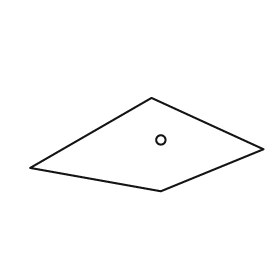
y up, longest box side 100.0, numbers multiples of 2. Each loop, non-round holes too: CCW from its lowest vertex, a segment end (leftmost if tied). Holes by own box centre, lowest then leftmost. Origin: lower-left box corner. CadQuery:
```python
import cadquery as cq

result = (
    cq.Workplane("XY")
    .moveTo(56.0, 0.0)
    .lineTo(100.0, 18.0)
    .lineTo(52.0, 40.0)
    .lineTo(0.0, 10.0)
    .close()
    .moveTo(56.0, 22.0)
    .circle(2.0)
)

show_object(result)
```